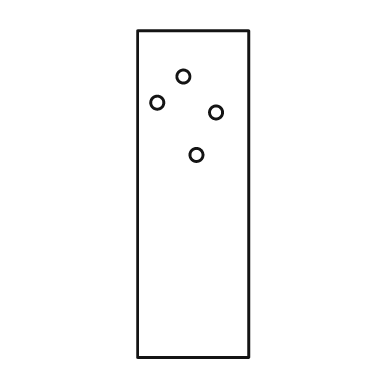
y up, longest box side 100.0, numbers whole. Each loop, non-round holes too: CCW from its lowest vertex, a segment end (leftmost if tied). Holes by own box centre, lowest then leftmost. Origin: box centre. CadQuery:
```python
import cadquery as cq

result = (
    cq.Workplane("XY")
    .moveTo(-17.0, -50.0)
    .lineTo(17.0, -50.0)
    .lineTo(17.0, 50.0)
    .lineTo(-17.0, 50.0)
    .close()
    .moveTo(1.0, 12.0)
    .circle(2.0)
    .moveTo(7.0, 25.0)
    .circle(2.0)
    .moveTo(-11.0, 28.0)
    .circle(2.0)
    .moveTo(-3.0, 36.0)
    .circle(2.0)
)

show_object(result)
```